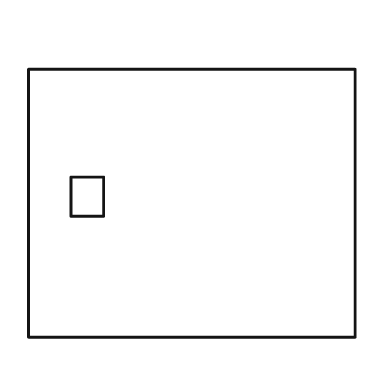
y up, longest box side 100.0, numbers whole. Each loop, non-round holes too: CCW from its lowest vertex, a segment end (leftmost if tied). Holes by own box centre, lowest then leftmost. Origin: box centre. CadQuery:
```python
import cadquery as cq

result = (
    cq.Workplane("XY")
    .moveTo(-50.0, -41.0)
    .lineTo(50.0, -41.0)
    .lineTo(50.0, 41.0)
    .lineTo(-50.0, 41.0)
    .close()
    .moveTo(-37.0, -4.0)
    .lineTo(-27.0, -4.0)
    .lineTo(-27.0, 8.0)
    .lineTo(-37.0, 8.0)
    .close()
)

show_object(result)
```